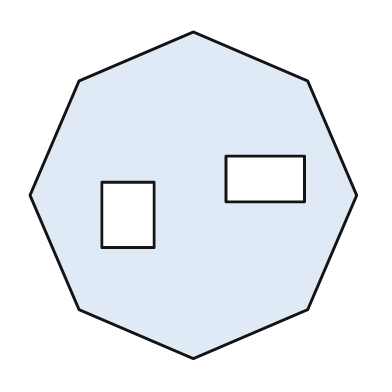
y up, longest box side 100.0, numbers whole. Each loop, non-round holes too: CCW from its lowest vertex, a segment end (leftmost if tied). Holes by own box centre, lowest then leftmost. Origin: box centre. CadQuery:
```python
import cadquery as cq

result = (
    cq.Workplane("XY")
    .moveTo(0.0, -50.0)
    .lineTo(35.0, -35.0)
    .lineTo(50.0, 0.0)
    .lineTo(35.0, 35.0)
    .lineTo(0.0, 50.0)
    .lineTo(-35.0, 35.0)
    .lineTo(-50.0, 0.0)
    .lineTo(-35.0, -35.0)
    .close()
    .moveTo(-28.0, -16.0)
    .lineTo(-12.0, -16.0)
    .lineTo(-12.0, 4.0)
    .lineTo(-28.0, 4.0)
    .close()
    .moveTo(10.0, -2.0)
    .lineTo(34.0, -2.0)
    .lineTo(34.0, 12.0)
    .lineTo(10.0, 12.0)
    .close()
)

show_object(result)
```